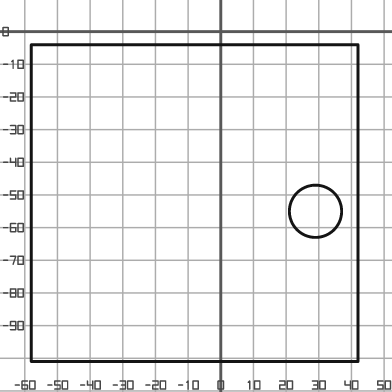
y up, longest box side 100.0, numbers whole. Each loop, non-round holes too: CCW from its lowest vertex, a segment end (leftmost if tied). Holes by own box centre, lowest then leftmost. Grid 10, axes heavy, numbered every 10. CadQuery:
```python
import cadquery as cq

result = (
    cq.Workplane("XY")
    .moveTo(-58.0, -101.0)
    .lineTo(42.0, -101.0)
    .lineTo(42.0, -4.0)
    .lineTo(-58.0, -4.0)
    .close()
    .moveTo(29.0, -55.0)
    .circle(8.0)
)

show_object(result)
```